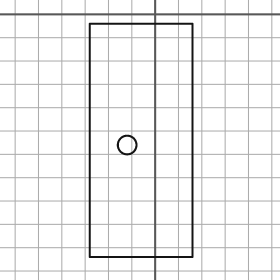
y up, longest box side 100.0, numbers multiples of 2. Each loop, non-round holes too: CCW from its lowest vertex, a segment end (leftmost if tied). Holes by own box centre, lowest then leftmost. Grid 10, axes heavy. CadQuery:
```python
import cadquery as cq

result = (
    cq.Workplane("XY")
    .moveTo(-28.0, -104.0)
    .lineTo(16.0, -104.0)
    .lineTo(16.0, -4.0)
    .lineTo(-28.0, -4.0)
    .close()
    .moveTo(-12.0, -56.0)
    .circle(4.0)
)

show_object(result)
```